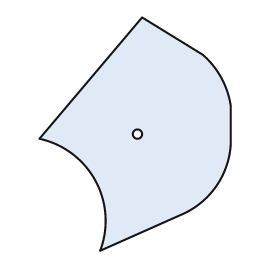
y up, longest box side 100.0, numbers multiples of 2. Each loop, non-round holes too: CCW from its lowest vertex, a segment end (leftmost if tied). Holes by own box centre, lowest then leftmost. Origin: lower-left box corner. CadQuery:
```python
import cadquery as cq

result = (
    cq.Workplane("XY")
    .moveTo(26.0, 0.0)
    .lineTo(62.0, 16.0)
    .threePointArc((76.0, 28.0), (82.0, 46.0))
    .lineTo(82.0, 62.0)
    .threePointArc((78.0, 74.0), (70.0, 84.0))
    .lineTo(44.0, 100.0)
    .lineTo(0.0, 48.0)
    .threePointArc((24.0, 30.0), (26.0, 0.0))
    .close()
    .moveTo(42.0, 50.0)
    .circle(2.0)
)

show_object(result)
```